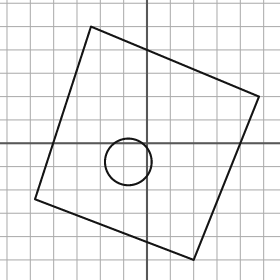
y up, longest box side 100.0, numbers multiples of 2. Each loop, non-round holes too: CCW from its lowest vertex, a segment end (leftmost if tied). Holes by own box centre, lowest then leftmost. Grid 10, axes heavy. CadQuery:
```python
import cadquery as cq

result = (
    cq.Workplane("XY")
    .moveTo(20.0, -50.0)
    .lineTo(48.0, 20.0)
    .lineTo(-24.0, 50.0)
    .lineTo(-48.0, -24.0)
    .close()
    .moveTo(-8.0, -8.0)
    .circle(10.0)
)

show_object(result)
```